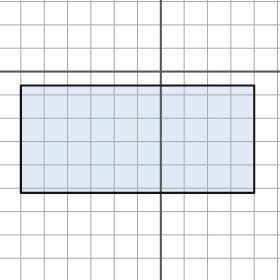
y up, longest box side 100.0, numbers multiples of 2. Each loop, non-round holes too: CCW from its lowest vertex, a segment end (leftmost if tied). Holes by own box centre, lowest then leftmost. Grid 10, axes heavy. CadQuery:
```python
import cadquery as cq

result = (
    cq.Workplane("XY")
    .moveTo(-60.0, -52.0)
    .lineTo(40.0, -52.0)
    .lineTo(40.0, -6.0)
    .lineTo(-60.0, -6.0)
    .close()
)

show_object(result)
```